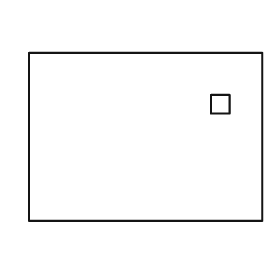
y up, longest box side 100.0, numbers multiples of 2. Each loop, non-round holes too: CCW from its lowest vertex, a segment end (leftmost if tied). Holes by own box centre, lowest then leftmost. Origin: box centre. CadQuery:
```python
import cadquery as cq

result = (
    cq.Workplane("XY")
    .moveTo(-50.0, -36.0)
    .lineTo(50.0, -36.0)
    .lineTo(50.0, 36.0)
    .lineTo(-50.0, 36.0)
    .close()
    .moveTo(28.0, 10.0)
    .lineTo(36.0, 10.0)
    .lineTo(36.0, 18.0)
    .lineTo(28.0, 18.0)
    .close()
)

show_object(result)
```